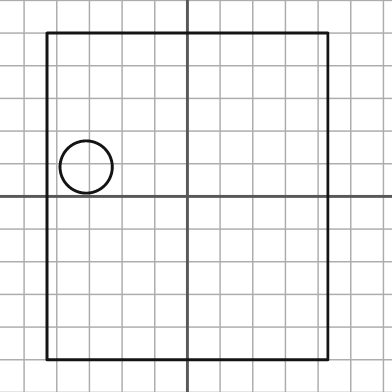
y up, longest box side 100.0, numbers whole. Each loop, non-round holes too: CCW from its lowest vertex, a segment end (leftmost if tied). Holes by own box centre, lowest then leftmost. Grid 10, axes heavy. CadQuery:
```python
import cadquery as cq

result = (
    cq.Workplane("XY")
    .moveTo(-43.0, -50.0)
    .lineTo(43.0, -50.0)
    .lineTo(43.0, 50.0)
    .lineTo(-43.0, 50.0)
    .close()
    .moveTo(-31.0, 9.0)
    .circle(8.0)
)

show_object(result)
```